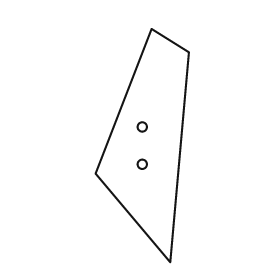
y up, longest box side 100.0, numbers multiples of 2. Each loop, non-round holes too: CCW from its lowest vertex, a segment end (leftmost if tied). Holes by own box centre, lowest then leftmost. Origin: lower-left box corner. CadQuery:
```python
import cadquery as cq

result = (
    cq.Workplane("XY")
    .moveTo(32.0, 0.0)
    .lineTo(40.0, 90.0)
    .lineTo(24.0, 100.0)
    .lineTo(0.0, 38.0)
    .close()
    .moveTo(20.0, 42.0)
    .circle(2.0)
    .moveTo(20.0, 58.0)
    .circle(2.0)
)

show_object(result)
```